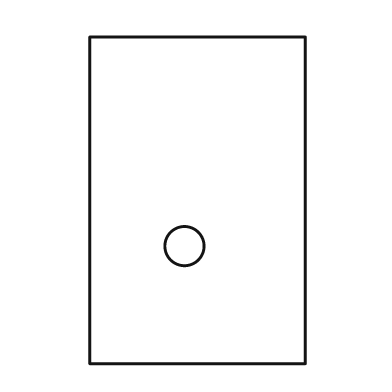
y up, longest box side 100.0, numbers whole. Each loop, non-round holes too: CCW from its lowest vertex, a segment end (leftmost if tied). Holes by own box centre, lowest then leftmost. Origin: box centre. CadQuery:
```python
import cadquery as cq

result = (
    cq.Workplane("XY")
    .moveTo(-33.0, -50.0)
    .lineTo(33.0, -50.0)
    .lineTo(33.0, 50.0)
    .lineTo(-33.0, 50.0)
    .close()
    .moveTo(-4.0, -14.0)
    .circle(6.0)
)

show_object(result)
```